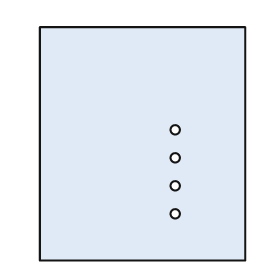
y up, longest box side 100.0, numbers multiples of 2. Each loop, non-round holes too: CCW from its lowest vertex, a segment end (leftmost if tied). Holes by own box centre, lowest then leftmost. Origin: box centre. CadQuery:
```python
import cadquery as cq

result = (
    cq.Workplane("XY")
    .moveTo(-44.0, -50.0)
    .lineTo(44.0, -50.0)
    .lineTo(44.0, 50.0)
    .lineTo(-44.0, 50.0)
    .close()
    .moveTo(14.0, -30.0)
    .circle(2.0)
    .moveTo(14.0, -18.0)
    .circle(2.0)
    .moveTo(14.0, -6.0)
    .circle(2.0)
    .moveTo(14.0, 6.0)
    .circle(2.0)
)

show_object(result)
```